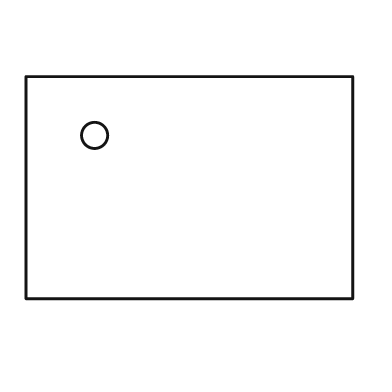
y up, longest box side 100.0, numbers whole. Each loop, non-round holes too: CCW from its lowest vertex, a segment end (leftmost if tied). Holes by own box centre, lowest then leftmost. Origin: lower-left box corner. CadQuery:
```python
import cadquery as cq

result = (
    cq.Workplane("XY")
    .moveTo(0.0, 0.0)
    .lineTo(100.0, 0.0)
    .lineTo(100.0, 68.0)
    .lineTo(0.0, 68.0)
    .close()
    .moveTo(21.0, 50.0)
    .circle(4.0)
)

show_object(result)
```